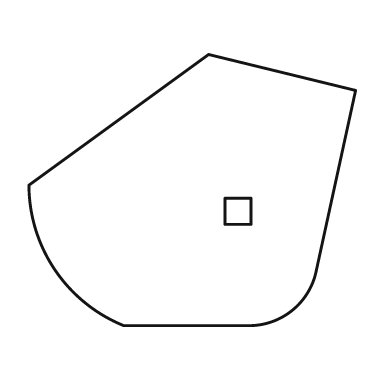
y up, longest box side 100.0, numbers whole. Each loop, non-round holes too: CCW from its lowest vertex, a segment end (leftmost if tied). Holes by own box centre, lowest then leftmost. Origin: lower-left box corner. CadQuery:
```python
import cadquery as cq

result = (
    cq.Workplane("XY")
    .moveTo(29.0, 0.0)
    .lineTo(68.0, 0.0)
    .threePointArc((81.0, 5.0), (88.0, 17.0))
    .lineTo(100.0, 72.0)
    .lineTo(55.0, 83.0)
    .lineTo(0.0, 43.0)
    .threePointArc((8.0, 17.0), (29.0, 0.0))
    .close()
    .moveTo(60.0, 31.0)
    .lineTo(68.0, 31.0)
    .lineTo(68.0, 39.0)
    .lineTo(60.0, 39.0)
    .close()
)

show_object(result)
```